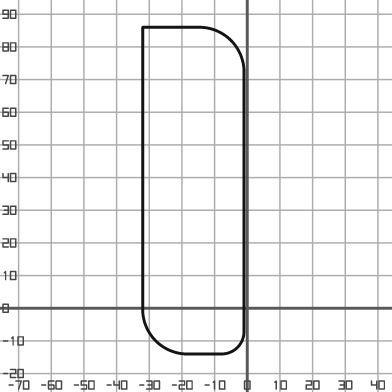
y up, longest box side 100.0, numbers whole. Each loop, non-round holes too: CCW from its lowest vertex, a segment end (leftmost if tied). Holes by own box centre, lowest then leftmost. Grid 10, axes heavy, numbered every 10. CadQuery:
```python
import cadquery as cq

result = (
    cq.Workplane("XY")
    .moveTo(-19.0, -14.0)
    .lineTo(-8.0, -14.0)
    .threePointArc((-3.0, -12.0), (-1.0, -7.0))
    .lineTo(-1.0, 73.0)
    .threePointArc((-5.0, 82.0), (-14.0, 86.0))
    .lineTo(-32.0, 86.0)
    .lineTo(-32.0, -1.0)
    .threePointArc((-28.0, -10.0), (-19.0, -14.0))
    .close()
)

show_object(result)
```